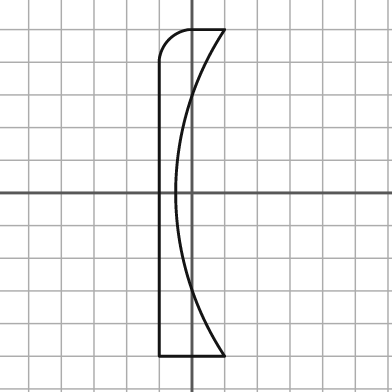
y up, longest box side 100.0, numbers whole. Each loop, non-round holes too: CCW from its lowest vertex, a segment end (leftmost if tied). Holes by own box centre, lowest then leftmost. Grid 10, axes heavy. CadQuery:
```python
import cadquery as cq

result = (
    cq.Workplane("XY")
    .moveTo(-10.0, -50.0)
    .lineTo(10.0, -50.0)
    .threePointArc((-5.0, 0.0), (10.0, 50.0))
    .lineTo(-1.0, 50.0)
    .threePointArc((-7.0, 47.0), (-10.0, 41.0))
    .close()
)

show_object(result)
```